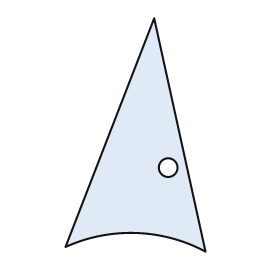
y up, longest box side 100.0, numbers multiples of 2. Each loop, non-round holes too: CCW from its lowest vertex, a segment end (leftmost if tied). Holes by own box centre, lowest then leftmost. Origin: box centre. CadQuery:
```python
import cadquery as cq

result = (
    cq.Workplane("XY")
    .moveTo(30.0, -50.0)
    .lineTo(8.0, 50.0)
    .lineTo(-30.0, -48.0)
    .threePointArc((0.0, -42.0), (30.0, -50.0))
    .close()
    .moveTo(14.0, -14.0)
    .circle(4.0)
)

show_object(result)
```